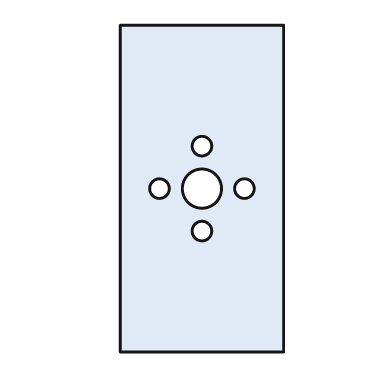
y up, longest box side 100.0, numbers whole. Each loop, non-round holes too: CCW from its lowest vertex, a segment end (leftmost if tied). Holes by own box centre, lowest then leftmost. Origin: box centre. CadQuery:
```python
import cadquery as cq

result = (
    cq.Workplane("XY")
    .moveTo(-25.0, -50.0)
    .lineTo(25.0, -50.0)
    .lineTo(25.0, 50.0)
    .lineTo(-25.0, 50.0)
    .close()
    .moveTo(0.0, -13.0)
    .circle(3.0)
    .moveTo(-13.0, 0.0)
    .circle(3.0)
    .moveTo(0.0, 0.0)
    .circle(6.0)
    .moveTo(13.0, 0.0)
    .circle(3.0)
    .moveTo(0.0, 13.0)
    .circle(3.0)
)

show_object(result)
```